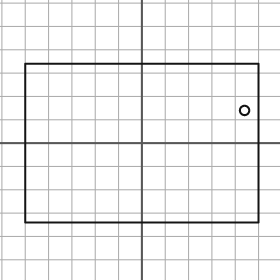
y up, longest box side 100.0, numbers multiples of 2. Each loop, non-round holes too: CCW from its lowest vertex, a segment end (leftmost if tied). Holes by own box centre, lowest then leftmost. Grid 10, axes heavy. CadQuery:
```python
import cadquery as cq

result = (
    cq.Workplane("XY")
    .moveTo(-50.0, -34.0)
    .lineTo(50.0, -34.0)
    .lineTo(50.0, 34.0)
    .lineTo(-50.0, 34.0)
    .close()
    .moveTo(44.0, 14.0)
    .circle(2.0)
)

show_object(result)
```